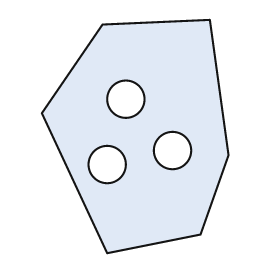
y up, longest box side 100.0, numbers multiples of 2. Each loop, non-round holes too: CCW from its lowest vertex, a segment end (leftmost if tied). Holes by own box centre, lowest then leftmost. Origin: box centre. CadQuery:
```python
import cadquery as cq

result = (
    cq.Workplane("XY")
    .moveTo(-12.0, -50.0)
    .lineTo(28.0, -42.0)
    .lineTo(40.0, -8.0)
    .lineTo(32.0, 50.0)
    .lineTo(-14.0, 48.0)
    .lineTo(-40.0, 10.0)
    .close()
    .moveTo(-12.0, -12.0)
    .circle(8.0)
    .moveTo(16.0, -6.0)
    .circle(8.0)
    .moveTo(-4.0, 16.0)
    .circle(8.0)
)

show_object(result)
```